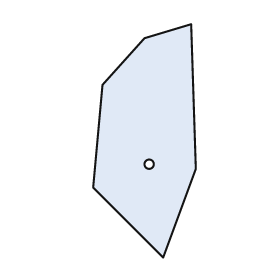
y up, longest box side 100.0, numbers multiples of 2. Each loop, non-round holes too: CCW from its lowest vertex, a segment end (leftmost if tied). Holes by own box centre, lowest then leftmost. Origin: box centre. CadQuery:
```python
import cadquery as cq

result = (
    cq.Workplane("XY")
    .moveTo(8.0, -50.0)
    .lineTo(22.0, -12.0)
    .lineTo(20.0, 50.0)
    .lineTo(0.0, 44.0)
    .lineTo(-18.0, 24.0)
    .lineTo(-22.0, -20.0)
    .close()
    .moveTo(2.0, -10.0)
    .circle(2.0)
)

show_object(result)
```